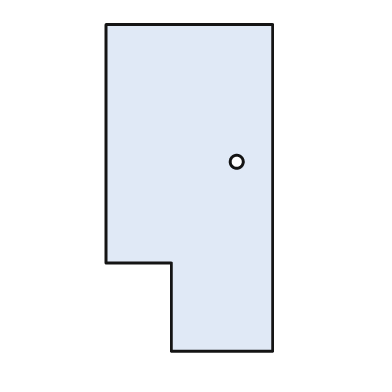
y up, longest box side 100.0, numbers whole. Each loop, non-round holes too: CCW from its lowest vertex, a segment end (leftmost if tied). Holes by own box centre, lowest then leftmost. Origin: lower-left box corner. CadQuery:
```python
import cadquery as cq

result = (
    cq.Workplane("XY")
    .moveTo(20.0, 0.0)
    .lineTo(51.0, 0.0)
    .lineTo(51.0, 100.0)
    .lineTo(0.0, 100.0)
    .lineTo(0.0, 27.0)
    .lineTo(20.0, 27.0)
    .close()
    .moveTo(40.0, 58.0)
    .circle(2.0)
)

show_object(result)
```